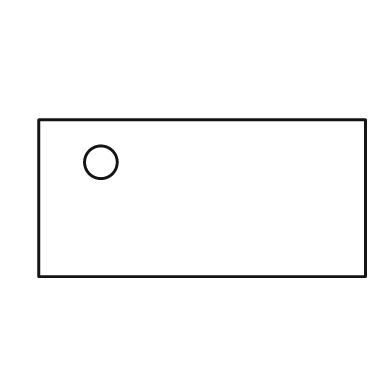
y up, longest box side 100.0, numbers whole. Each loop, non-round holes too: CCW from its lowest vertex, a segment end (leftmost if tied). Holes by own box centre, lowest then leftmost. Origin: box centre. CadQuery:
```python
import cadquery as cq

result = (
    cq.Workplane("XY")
    .moveTo(-50.0, -24.0)
    .lineTo(50.0, -24.0)
    .lineTo(50.0, 24.0)
    .lineTo(-50.0, 24.0)
    .close()
    .moveTo(-31.0, 11.0)
    .circle(5.0)
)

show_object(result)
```